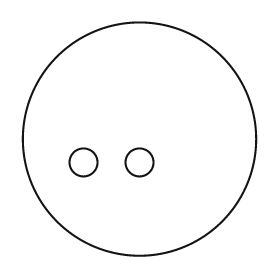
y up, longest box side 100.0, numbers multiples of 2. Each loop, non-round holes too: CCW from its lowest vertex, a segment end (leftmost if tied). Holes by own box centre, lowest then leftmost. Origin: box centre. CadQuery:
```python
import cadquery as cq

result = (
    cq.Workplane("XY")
    .moveTo(0.0, 0.0)
    .circle(50.0)
    .moveTo(-24.0, -10.0)
    .circle(6.0)
    .moveTo(0.0, -10.0)
    .circle(6.0)
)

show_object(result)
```